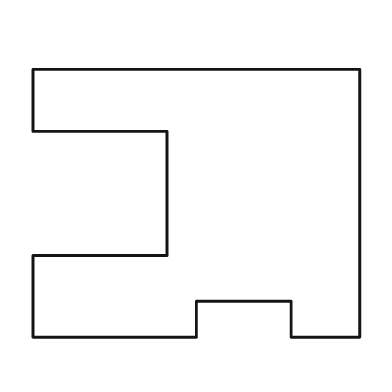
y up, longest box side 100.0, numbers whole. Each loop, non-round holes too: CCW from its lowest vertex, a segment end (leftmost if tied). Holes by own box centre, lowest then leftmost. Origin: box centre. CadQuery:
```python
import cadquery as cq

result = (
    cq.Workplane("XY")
    .moveTo(-50.0, -41.0)
    .lineTo(0.0, -41.0)
    .lineTo(0.0, -30.0)
    .lineTo(29.0, -30.0)
    .lineTo(29.0, -41.0)
    .lineTo(50.0, -41.0)
    .lineTo(50.0, 41.0)
    .lineTo(-50.0, 41.0)
    .lineTo(-50.0, 22.0)
    .lineTo(-9.0, 22.0)
    .lineTo(-9.0, -16.0)
    .lineTo(-50.0, -16.0)
    .close()
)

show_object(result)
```